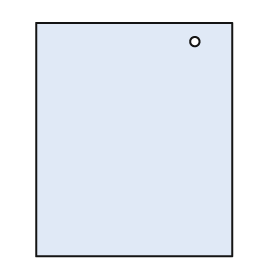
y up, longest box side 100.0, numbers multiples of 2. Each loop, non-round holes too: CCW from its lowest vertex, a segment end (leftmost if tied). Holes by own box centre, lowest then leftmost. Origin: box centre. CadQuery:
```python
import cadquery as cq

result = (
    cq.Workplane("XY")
    .moveTo(-42.0, -50.0)
    .lineTo(42.0, -50.0)
    .lineTo(42.0, 50.0)
    .lineTo(-42.0, 50.0)
    .close()
    .moveTo(26.0, 42.0)
    .circle(2.0)
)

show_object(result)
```